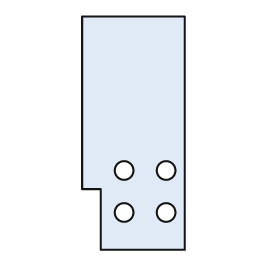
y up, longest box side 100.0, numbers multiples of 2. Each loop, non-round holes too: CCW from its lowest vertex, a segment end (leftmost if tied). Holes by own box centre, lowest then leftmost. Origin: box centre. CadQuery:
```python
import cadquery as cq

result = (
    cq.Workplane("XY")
    .moveTo(-14.0, -50.0)
    .lineTo(22.0, -50.0)
    .lineTo(22.0, 50.0)
    .lineTo(-22.0, 50.0)
    .lineTo(-22.0, -24.0)
    .lineTo(-14.0, -24.0)
    .close()
    .moveTo(-4.0, -34.0)
    .circle(4.0)
    .moveTo(14.0, -34.0)
    .circle(4.0)
    .moveTo(-4.0, -16.0)
    .circle(4.0)
    .moveTo(14.0, -16.0)
    .circle(4.0)
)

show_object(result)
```